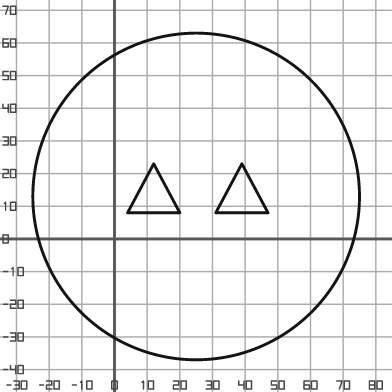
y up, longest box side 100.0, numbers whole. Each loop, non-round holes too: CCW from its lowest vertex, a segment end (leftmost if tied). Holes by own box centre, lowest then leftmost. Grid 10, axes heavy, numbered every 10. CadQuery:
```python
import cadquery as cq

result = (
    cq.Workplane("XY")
    .moveTo(25.0, 13.0)
    .circle(50.0)
    .moveTo(4.0, 8.0)
    .lineTo(20.0, 8.0)
    .lineTo(12.0, 23.0)
    .close()
    .moveTo(31.0, 8.0)
    .lineTo(47.0, 8.0)
    .lineTo(39.0, 23.0)
    .close()
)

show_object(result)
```